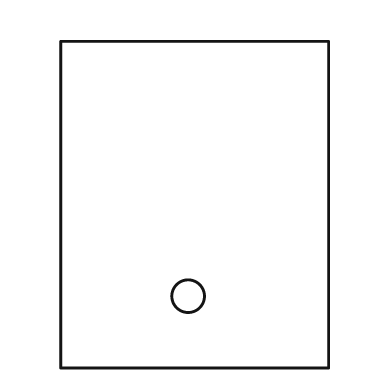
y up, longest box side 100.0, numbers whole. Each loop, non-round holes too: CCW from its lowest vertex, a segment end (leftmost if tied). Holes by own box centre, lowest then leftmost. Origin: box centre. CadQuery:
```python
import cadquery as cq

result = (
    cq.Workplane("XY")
    .moveTo(-41.0, -50.0)
    .lineTo(41.0, -50.0)
    .lineTo(41.0, 50.0)
    .lineTo(-41.0, 50.0)
    .close()
    .moveTo(-2.0, -28.0)
    .circle(5.0)
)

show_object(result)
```